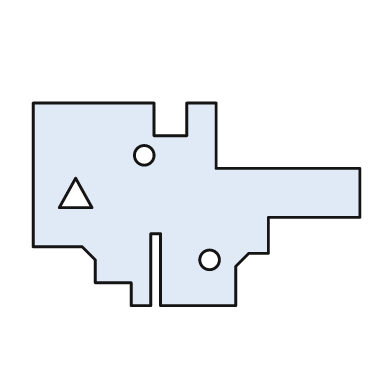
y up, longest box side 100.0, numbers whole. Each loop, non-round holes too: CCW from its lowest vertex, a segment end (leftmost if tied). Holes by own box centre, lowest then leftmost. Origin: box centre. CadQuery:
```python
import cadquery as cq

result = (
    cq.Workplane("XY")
    .moveTo(-20.0, -31.0)
    .lineTo(-14.0, -31.0)
    .lineTo(-14.0, -9.0)
    .lineTo(-11.0, -9.0)
    .lineTo(-11.0, -31.0)
    .lineTo(12.0, -31.0)
    .lineTo(12.0, -19.0)
    .lineTo(16.0, -15.0)
    .lineTo(22.0, -15.0)
    .lineTo(22.0, -4.0)
    .lineTo(50.0, -4.0)
    .lineTo(50.0, 11.0)
    .lineTo(6.0, 11.0)
    .lineTo(6.0, 31.0)
    .lineTo(-3.0, 31.0)
    .lineTo(-3.0, 21.0)
    .lineTo(-13.0, 21.0)
    .lineTo(-13.0, 31.0)
    .lineTo(-50.0, 31.0)
    .lineTo(-50.0, -13.0)
    .lineTo(-35.0, -13.0)
    .lineTo(-31.0, -17.0)
    .lineTo(-31.0, -24.0)
    .lineTo(-20.0, -24.0)
    .close()
    .moveTo(4.0, -17.0)
    .circle(3.0)
    .moveTo(-42.0, -1.0)
    .lineTo(-32.0, -1.0)
    .lineTo(-37.0, 8.0)
    .close()
    .moveTo(-16.0, 15.0)
    .circle(3.0)
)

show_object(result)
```